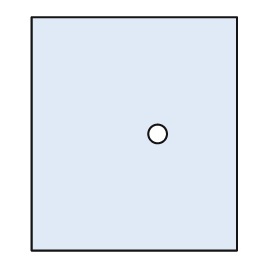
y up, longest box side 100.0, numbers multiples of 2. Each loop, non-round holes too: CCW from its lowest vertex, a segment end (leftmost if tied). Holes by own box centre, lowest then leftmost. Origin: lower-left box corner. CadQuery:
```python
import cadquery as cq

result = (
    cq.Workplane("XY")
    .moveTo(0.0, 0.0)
    .lineTo(88.0, 0.0)
    .lineTo(88.0, 100.0)
    .lineTo(0.0, 100.0)
    .close()
    .moveTo(54.0, 50.0)
    .circle(4.0)
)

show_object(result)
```